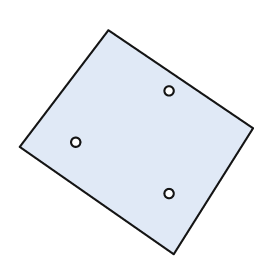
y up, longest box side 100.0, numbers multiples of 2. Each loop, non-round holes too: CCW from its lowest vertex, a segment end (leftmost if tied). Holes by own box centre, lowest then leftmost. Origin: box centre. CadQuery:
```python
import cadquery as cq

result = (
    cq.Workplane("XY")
    .moveTo(16.0, -48.0)
    .lineTo(50.0, 6.0)
    .lineTo(-12.0, 48.0)
    .lineTo(-50.0, -2.0)
    .close()
    .moveTo(14.0, -22.0)
    .circle(2.0)
    .moveTo(-26.0, 0.0)
    .circle(2.0)
    .moveTo(14.0, 22.0)
    .circle(2.0)
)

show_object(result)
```